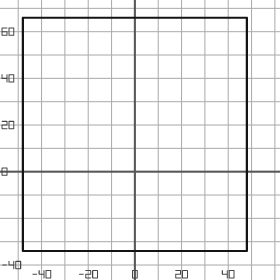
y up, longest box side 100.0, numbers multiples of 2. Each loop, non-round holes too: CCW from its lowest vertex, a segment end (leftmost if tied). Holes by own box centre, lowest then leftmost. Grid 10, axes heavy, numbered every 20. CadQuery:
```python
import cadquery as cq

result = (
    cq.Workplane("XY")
    .moveTo(-48.0, -34.0)
    .lineTo(48.0, -34.0)
    .lineTo(48.0, 66.0)
    .lineTo(-48.0, 66.0)
    .close()
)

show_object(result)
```